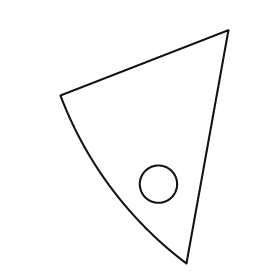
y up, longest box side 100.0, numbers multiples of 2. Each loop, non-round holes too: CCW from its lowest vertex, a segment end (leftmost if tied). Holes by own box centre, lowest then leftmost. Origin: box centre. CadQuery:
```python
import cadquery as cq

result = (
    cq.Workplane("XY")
    .moveTo(18.0, -50.0)
    .lineTo(36.0, 50.0)
    .lineTo(-36.0, 22.0)
    .threePointArc((-14.0, -18.0), (18.0, -50.0))
    .close()
    .moveTo(6.0, -16.0)
    .circle(8.0)
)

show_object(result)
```